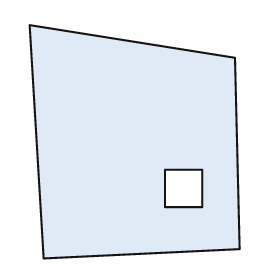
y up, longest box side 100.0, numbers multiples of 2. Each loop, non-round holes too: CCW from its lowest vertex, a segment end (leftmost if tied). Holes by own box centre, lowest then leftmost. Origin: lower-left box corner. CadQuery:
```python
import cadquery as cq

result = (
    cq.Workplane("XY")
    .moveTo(6.0, 0.0)
    .lineTo(90.0, 4.0)
    .lineTo(88.0, 86.0)
    .lineTo(0.0, 100.0)
    .close()
    .moveTo(58.0, 22.0)
    .lineTo(74.0, 22.0)
    .lineTo(74.0, 38.0)
    .lineTo(58.0, 38.0)
    .close()
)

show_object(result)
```